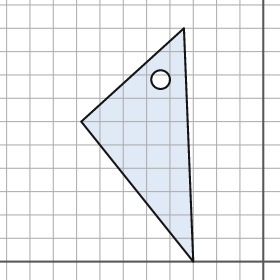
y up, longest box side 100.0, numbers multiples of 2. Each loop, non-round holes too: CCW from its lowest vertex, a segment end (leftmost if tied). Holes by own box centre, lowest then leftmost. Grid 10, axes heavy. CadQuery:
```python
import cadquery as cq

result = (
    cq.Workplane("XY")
    .moveTo(-30.0, 0.0)
    .lineTo(-34.0, 100.0)
    .lineTo(-78.0, 60.0)
    .close()
    .moveTo(-44.0, 78.0)
    .circle(4.0)
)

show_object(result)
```